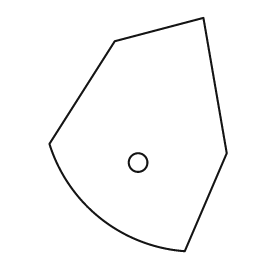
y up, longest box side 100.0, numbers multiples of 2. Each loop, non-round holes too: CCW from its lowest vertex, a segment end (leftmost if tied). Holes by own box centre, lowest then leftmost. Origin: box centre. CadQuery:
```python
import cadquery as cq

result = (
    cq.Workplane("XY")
    .moveTo(20.0, -50.0)
    .lineTo(38.0, -8.0)
    .lineTo(28.0, 50.0)
    .lineTo(-10.0, 40.0)
    .lineTo(-38.0, -4.0)
    .threePointArc((-16.0, -36.0), (20.0, -50.0))
    .close()
    .moveTo(0.0, -12.0)
    .circle(4.0)
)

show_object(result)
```